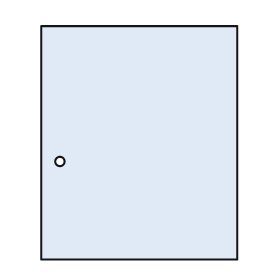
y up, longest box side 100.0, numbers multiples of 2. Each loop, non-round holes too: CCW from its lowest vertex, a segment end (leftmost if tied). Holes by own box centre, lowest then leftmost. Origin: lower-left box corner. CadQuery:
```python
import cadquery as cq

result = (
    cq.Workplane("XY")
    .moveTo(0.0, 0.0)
    .lineTo(84.0, 0.0)
    .lineTo(84.0, 100.0)
    .lineTo(0.0, 100.0)
    .close()
    .moveTo(8.0, 42.0)
    .circle(2.0)
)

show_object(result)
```